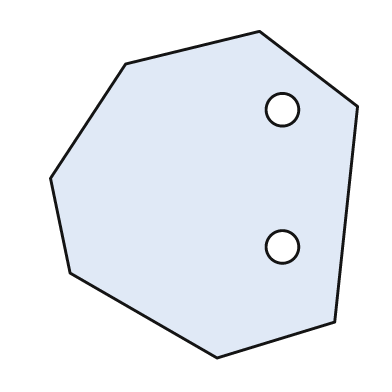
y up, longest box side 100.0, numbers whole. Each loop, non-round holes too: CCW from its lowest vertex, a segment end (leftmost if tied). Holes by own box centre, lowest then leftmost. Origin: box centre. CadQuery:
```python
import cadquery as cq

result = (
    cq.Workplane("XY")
    .moveTo(4.0, -50.0)
    .lineTo(40.0, -39.0)
    .lineTo(47.0, 27.0)
    .lineTo(17.0, 50.0)
    .lineTo(-24.0, 40.0)
    .lineTo(-47.0, 5.0)
    .lineTo(-41.0, -24.0)
    .close()
    .moveTo(24.0, -16.0)
    .circle(5.0)
    .moveTo(24.0, 26.0)
    .circle(5.0)
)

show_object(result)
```